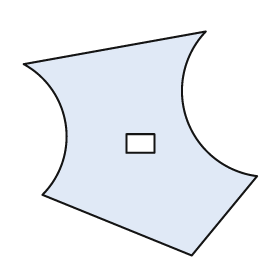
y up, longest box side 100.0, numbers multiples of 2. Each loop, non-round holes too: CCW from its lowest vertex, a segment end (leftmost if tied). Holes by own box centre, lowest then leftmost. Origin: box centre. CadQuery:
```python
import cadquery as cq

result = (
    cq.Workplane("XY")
    .moveTo(22.0, -48.0)
    .lineTo(50.0, -14.0)
    .threePointArc((20.0, 10.0), (28.0, 48.0))
    .lineTo(-50.0, 34.0)
    .threePointArc((-32.0, 8.0), (-42.0, -22.0))
    .close()
    .moveTo(-6.0, -4.0)
    .lineTo(6.0, -4.0)
    .lineTo(6.0, 4.0)
    .lineTo(-6.0, 4.0)
    .close()
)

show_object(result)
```